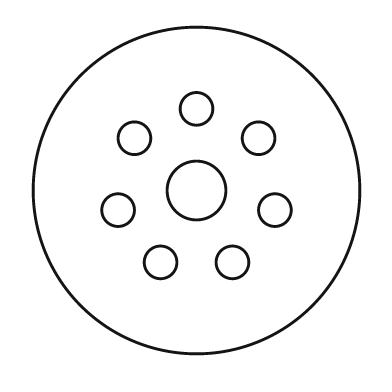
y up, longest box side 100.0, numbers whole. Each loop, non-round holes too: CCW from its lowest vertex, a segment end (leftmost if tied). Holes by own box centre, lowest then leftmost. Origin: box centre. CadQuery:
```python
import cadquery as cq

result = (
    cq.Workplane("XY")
    .moveTo(0.0, 0.0)
    .circle(50.0)
    .moveTo(-11.0, -22.0)
    .circle(5.0)
    .moveTo(11.0, -22.0)
    .circle(5.0)
    .moveTo(-24.0, -6.0)
    .circle(5.0)
    .moveTo(24.0, -6.0)
    .circle(5.0)
    .moveTo(0.0, 0.0)
    .circle(9.0)
    .moveTo(-19.0, 16.0)
    .circle(5.0)
    .moveTo(19.0, 16.0)
    .circle(5.0)
    .moveTo(0.0, 25.0)
    .circle(5.0)
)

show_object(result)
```